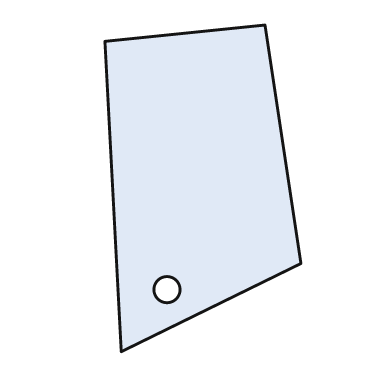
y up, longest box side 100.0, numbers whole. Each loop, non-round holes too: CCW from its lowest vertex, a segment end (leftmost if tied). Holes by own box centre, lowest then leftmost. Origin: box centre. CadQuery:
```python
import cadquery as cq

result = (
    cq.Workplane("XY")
    .moveTo(-25.0, -50.0)
    .lineTo(30.0, -23.0)
    .lineTo(19.0, 50.0)
    .lineTo(-30.0, 45.0)
    .close()
    .moveTo(-11.0, -31.0)
    .circle(4.0)
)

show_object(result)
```